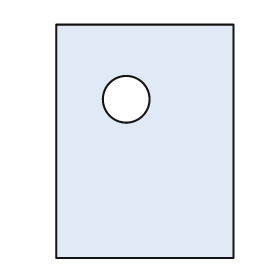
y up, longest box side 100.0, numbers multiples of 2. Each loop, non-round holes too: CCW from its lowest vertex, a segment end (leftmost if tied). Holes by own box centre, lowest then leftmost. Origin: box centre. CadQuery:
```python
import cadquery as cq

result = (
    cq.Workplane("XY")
    .moveTo(-38.0, -50.0)
    .lineTo(38.0, -50.0)
    .lineTo(38.0, 50.0)
    .lineTo(-38.0, 50.0)
    .close()
    .moveTo(-8.0, 18.0)
    .circle(10.0)
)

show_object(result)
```